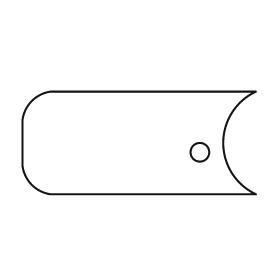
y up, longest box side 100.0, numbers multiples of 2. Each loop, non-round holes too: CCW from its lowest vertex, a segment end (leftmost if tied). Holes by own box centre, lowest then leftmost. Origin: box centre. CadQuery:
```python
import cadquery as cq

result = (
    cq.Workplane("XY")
    .moveTo(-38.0, -22.0)
    .lineTo(50.0, -22.0)
    .threePointArc((36.0, 0.0), (50.0, 22.0))
    .lineTo(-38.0, 22.0)
    .threePointArc((-46.0, 18.0), (-50.0, 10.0))
    .lineTo(-50.0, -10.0)
    .threePointArc((-46.0, -18.0), (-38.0, -22.0))
    .close()
    .moveTo(26.0, -4.0)
    .circle(4.0)
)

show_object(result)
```